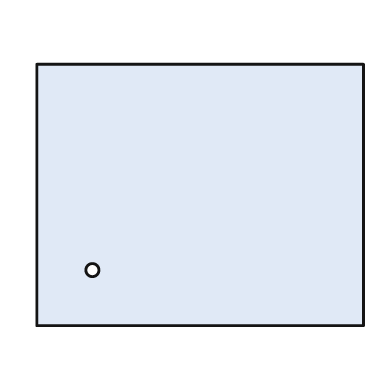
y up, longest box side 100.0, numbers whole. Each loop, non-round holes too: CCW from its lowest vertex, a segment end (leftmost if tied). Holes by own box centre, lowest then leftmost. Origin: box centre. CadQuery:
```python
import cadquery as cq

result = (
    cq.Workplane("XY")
    .moveTo(-50.0, -40.0)
    .lineTo(50.0, -40.0)
    .lineTo(50.0, 40.0)
    .lineTo(-50.0, 40.0)
    .close()
    .moveTo(-33.0, -23.0)
    .circle(2.0)
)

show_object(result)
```